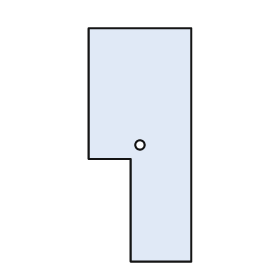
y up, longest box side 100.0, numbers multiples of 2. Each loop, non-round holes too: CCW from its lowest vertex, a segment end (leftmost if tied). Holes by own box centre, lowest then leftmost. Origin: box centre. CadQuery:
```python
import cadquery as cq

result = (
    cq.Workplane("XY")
    .moveTo(-4.0, -50.0)
    .lineTo(22.0, -50.0)
    .lineTo(22.0, 50.0)
    .lineTo(-22.0, 50.0)
    .lineTo(-22.0, -6.0)
    .lineTo(-4.0, -6.0)
    .close()
    .moveTo(0.0, 0.0)
    .circle(2.0)
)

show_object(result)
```